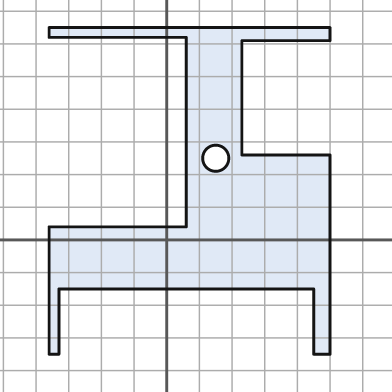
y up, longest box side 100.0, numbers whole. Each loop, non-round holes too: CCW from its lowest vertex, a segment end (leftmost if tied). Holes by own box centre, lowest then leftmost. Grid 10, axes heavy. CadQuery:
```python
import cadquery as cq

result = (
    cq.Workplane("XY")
    .moveTo(-36.0, -35.0)
    .lineTo(-33.0, -35.0)
    .lineTo(-33.0, -15.0)
    .lineTo(45.0, -15.0)
    .lineTo(45.0, -35.0)
    .lineTo(50.0, -35.0)
    .lineTo(50.0, 26.0)
    .lineTo(23.0, 26.0)
    .lineTo(23.0, 61.0)
    .lineTo(50.0, 61.0)
    .lineTo(50.0, 65.0)
    .lineTo(-36.0, 65.0)
    .lineTo(-36.0, 62.0)
    .lineTo(6.0, 62.0)
    .lineTo(6.0, 4.0)
    .lineTo(-36.0, 4.0)
    .close()
    .moveTo(15.0, 25.0)
    .circle(4.0)
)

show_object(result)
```